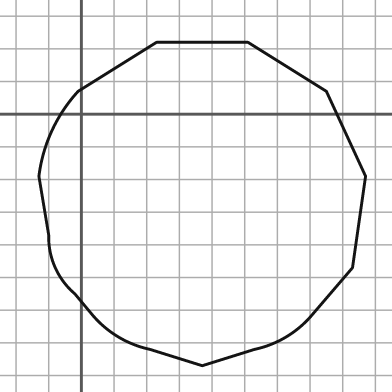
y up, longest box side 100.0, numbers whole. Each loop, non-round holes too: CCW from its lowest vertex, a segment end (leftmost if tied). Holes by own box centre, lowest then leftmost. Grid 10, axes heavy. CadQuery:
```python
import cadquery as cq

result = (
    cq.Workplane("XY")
    .moveTo(37.0, -77.0)
    .lineTo(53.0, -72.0)
    .threePointArc((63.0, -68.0), (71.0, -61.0))
    .lineTo(83.0, -47.0)
    .lineTo(87.0, -19.0)
    .lineTo(75.0, 7.0)
    .lineTo(51.0, 22.0)
    .lineTo(23.0, 22.0)
    .lineTo(-1.0, 7.0)
    .threePointArc((-9.0, -5.0), (-13.0, -19.0))
    .lineTo(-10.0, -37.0)
    .threePointArc((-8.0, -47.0), (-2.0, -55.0))
    .lineTo(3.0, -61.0)
    .threePointArc((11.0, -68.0), (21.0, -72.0))
    .close()
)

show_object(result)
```